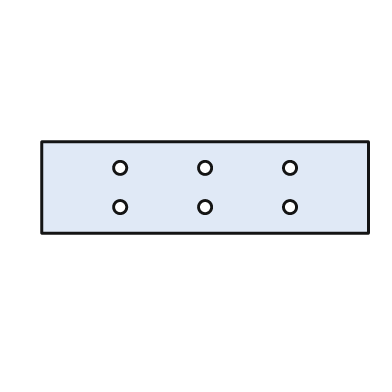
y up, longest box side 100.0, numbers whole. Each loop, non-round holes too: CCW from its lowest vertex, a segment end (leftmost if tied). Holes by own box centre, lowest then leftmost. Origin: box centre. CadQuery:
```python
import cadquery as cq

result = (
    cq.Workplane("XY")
    .moveTo(-50.0, -14.0)
    .lineTo(50.0, -14.0)
    .lineTo(50.0, 14.0)
    .lineTo(-50.0, 14.0)
    .close()
    .moveTo(-26.0, -6.0)
    .circle(2.0)
    .moveTo(0.0, -6.0)
    .circle(2.0)
    .moveTo(26.0, -6.0)
    .circle(2.0)
    .moveTo(-26.0, 6.0)
    .circle(2.0)
    .moveTo(0.0, 6.0)
    .circle(2.0)
    .moveTo(26.0, 6.0)
    .circle(2.0)
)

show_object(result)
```